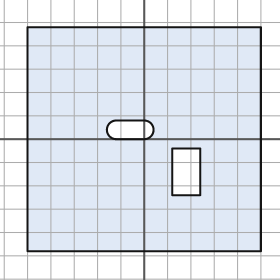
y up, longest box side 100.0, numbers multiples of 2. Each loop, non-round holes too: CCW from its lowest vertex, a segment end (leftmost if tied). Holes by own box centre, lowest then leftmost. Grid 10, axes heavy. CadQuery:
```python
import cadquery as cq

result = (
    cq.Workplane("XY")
    .moveTo(-50.0, -48.0)
    .lineTo(50.0, -48.0)
    .lineTo(50.0, 48.0)
    .lineTo(-50.0, 48.0)
    .close()
    .moveTo(12.0, -24.0)
    .lineTo(24.0, -24.0)
    .lineTo(24.0, -4.0)
    .lineTo(12.0, -4.0)
    .close()
    .moveTo(-12.0, 0.0)
    .lineTo(0.0, 0.0)
    .threePointArc((4.0, 4.0), (0.0, 8.0))
    .lineTo(-12.0, 8.0)
    .threePointArc((-16.0, 4.0), (-12.0, 0.0))
    .close()
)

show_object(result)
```